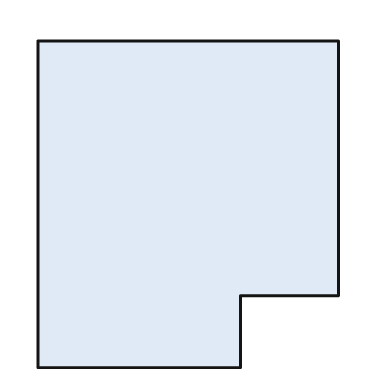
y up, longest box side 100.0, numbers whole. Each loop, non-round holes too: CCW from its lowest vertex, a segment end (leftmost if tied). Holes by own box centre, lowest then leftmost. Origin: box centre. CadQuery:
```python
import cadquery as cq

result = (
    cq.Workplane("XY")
    .moveTo(-46.0, -50.0)
    .lineTo(16.0, -50.0)
    .lineTo(16.0, -28.0)
    .lineTo(46.0, -28.0)
    .lineTo(46.0, 50.0)
    .lineTo(-46.0, 50.0)
    .close()
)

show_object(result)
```